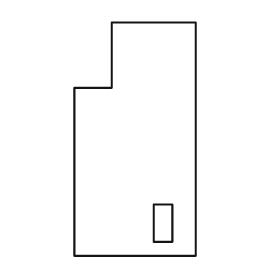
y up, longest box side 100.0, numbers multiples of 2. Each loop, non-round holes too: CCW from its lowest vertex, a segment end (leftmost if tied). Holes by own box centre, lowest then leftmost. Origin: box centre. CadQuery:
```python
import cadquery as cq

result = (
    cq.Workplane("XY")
    .moveTo(-26.0, -50.0)
    .lineTo(26.0, -50.0)
    .lineTo(26.0, 50.0)
    .lineTo(-10.0, 50.0)
    .lineTo(-10.0, 22.0)
    .lineTo(-26.0, 22.0)
    .close()
    .moveTo(8.0, -44.0)
    .lineTo(16.0, -44.0)
    .lineTo(16.0, -28.0)
    .lineTo(8.0, -28.0)
    .close()
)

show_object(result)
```